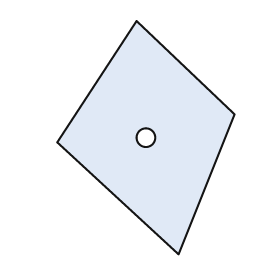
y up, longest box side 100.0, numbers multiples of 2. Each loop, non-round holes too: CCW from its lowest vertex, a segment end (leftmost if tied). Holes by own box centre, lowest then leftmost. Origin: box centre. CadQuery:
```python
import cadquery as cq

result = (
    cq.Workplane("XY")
    .moveTo(14.0, -50.0)
    .lineTo(38.0, 10.0)
    .lineTo(-4.0, 50.0)
    .lineTo(-38.0, -2.0)
    .close()
    .moveTo(0.0, 0.0)
    .circle(4.0)
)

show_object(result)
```